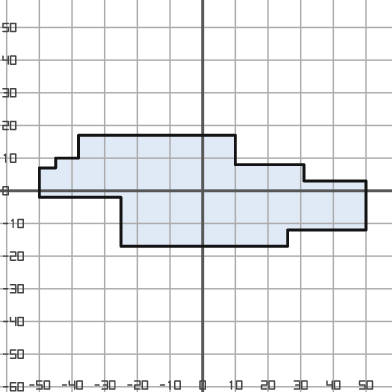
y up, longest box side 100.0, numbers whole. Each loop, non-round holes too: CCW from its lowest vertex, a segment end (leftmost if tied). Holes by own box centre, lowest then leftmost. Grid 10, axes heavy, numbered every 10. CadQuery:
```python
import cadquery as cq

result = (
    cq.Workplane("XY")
    .moveTo(-25.0, -17.0)
    .lineTo(26.0, -17.0)
    .lineTo(26.0, -12.0)
    .lineTo(50.0, -12.0)
    .lineTo(50.0, 3.0)
    .lineTo(31.0, 3.0)
    .lineTo(31.0, 8.0)
    .lineTo(10.0, 8.0)
    .lineTo(10.0, 17.0)
    .lineTo(-38.0, 17.0)
    .lineTo(-38.0, 10.0)
    .lineTo(-45.0, 10.0)
    .lineTo(-45.0, 7.0)
    .lineTo(-50.0, 7.0)
    .lineTo(-50.0, -2.0)
    .lineTo(-25.0, -2.0)
    .close()
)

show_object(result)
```